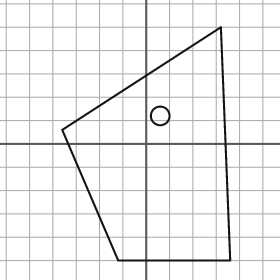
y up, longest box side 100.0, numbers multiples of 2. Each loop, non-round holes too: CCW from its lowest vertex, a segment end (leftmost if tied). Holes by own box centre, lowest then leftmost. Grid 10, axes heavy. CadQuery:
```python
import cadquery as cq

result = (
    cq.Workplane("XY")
    .moveTo(-12.0, -50.0)
    .lineTo(36.0, -50.0)
    .lineTo(32.0, 50.0)
    .lineTo(-36.0, 6.0)
    .close()
    .moveTo(6.0, 12.0)
    .circle(4.0)
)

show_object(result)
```